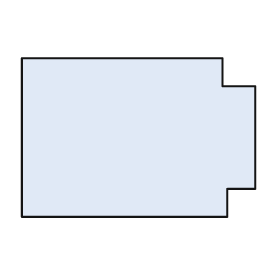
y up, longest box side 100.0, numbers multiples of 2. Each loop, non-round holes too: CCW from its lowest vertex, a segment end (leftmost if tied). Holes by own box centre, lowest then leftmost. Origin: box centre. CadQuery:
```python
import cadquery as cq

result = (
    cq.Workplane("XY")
    .moveTo(-50.0, -34.0)
    .lineTo(38.0, -34.0)
    .lineTo(38.0, -22.0)
    .lineTo(50.0, -22.0)
    .lineTo(50.0, 22.0)
    .lineTo(36.0, 22.0)
    .lineTo(36.0, 34.0)
    .lineTo(-50.0, 34.0)
    .close()
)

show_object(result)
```